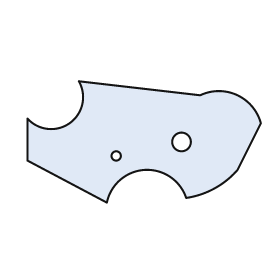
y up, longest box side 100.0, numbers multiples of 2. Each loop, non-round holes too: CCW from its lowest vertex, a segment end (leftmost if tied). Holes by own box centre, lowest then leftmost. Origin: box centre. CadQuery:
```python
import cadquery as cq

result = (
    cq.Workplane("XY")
    .moveTo(-16.0, -26.0)
    .threePointArc((0.0, -12.0), (18.0, -24.0))
    .threePointArc((30.0, -20.0), (40.0, -12.0))
    .lineTo(50.0, 8.0)
    .threePointArc((40.0, 20.0), (24.0, 20.0))
    .lineTo(-28.0, 26.0)
    .threePointArc((-32.0, 8.0), (-50.0, 10.0))
    .lineTo(-50.0, -8.0)
    .close()
    .moveTo(-12.0, -6.0)
    .circle(2.0)
    .moveTo(16.0, 0.0)
    .circle(4.0)
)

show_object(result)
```